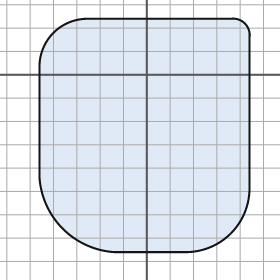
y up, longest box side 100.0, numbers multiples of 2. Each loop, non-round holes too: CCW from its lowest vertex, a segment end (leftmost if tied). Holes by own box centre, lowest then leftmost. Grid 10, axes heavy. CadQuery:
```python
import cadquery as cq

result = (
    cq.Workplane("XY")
    .moveTo(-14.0, -76.0)
    .lineTo(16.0, -76.0)
    .threePointArc((36.0, -68.0), (44.0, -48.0))
    .lineTo(44.0, 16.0)
    .threePointArc((42.0, 22.0), (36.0, 24.0))
    .lineTo(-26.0, 24.0)
    .threePointArc((-40.0, 18.0), (-46.0, 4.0))
    .lineTo(-46.0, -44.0)
    .threePointArc((-36.0, -66.0), (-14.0, -76.0))
    .close()
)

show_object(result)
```